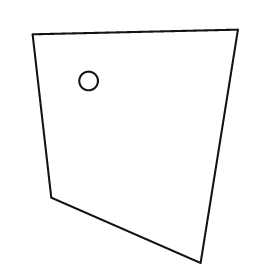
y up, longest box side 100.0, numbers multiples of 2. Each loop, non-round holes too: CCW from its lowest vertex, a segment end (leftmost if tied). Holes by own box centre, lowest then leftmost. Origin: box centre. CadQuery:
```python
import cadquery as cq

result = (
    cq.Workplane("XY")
    .moveTo(28.0, -50.0)
    .lineTo(44.0, 50.0)
    .lineTo(-44.0, 48.0)
    .lineTo(-36.0, -22.0)
    .close()
    .moveTo(-20.0, 28.0)
    .circle(4.0)
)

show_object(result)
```